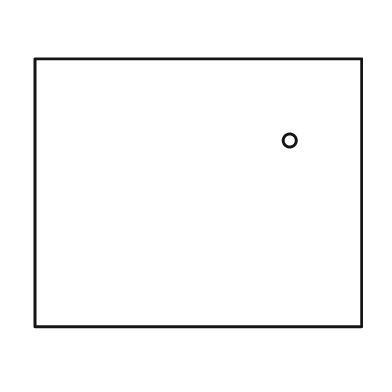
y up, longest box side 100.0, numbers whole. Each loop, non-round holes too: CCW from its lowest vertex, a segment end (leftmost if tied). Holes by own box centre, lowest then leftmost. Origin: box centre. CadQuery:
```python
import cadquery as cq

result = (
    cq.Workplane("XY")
    .moveTo(-50.0, -41.0)
    .lineTo(50.0, -41.0)
    .lineTo(50.0, 41.0)
    .lineTo(-50.0, 41.0)
    .close()
    .moveTo(28.0, 16.0)
    .circle(2.0)
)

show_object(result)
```